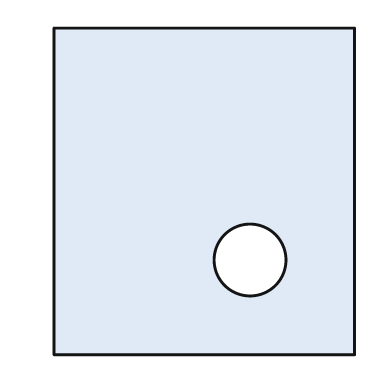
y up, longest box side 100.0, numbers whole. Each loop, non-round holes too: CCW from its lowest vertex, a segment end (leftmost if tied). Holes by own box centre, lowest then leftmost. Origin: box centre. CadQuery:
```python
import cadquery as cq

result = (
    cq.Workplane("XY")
    .moveTo(-46.0, -50.0)
    .lineTo(46.0, -50.0)
    .lineTo(46.0, 50.0)
    .lineTo(-46.0, 50.0)
    .close()
    .moveTo(14.0, -21.0)
    .circle(11.0)
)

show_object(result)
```